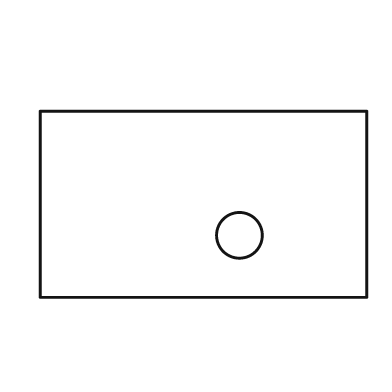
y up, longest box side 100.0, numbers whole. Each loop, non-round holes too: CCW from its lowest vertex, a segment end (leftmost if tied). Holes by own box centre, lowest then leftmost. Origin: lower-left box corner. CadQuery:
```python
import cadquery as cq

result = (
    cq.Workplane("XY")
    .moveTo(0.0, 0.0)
    .lineTo(100.0, 0.0)
    .lineTo(100.0, 57.0)
    .lineTo(0.0, 57.0)
    .close()
    .moveTo(61.0, 19.0)
    .circle(7.0)
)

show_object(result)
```